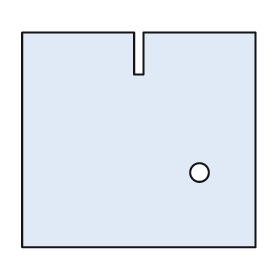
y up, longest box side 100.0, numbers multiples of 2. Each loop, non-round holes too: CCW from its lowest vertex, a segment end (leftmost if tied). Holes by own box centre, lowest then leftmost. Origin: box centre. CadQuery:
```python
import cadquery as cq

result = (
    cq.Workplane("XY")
    .moveTo(-50.0, -46.0)
    .lineTo(50.0, -46.0)
    .lineTo(50.0, 46.0)
    .lineTo(2.0, 46.0)
    .lineTo(2.0, 28.0)
    .lineTo(-2.0, 28.0)
    .lineTo(-2.0, 46.0)
    .lineTo(-50.0, 46.0)
    .close()
    .moveTo(26.0, -14.0)
    .circle(4.0)
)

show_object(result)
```